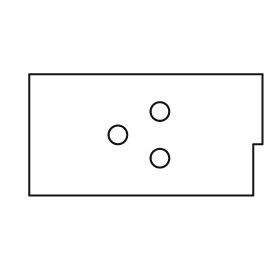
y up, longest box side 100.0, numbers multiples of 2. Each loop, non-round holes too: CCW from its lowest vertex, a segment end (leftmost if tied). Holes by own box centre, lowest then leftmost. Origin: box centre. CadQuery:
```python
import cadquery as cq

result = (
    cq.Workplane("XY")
    .moveTo(-50.0, -26.0)
    .lineTo(46.0, -26.0)
    .lineTo(46.0, -4.0)
    .lineTo(50.0, -4.0)
    .lineTo(50.0, 26.0)
    .lineTo(-50.0, 26.0)
    .close()
    .moveTo(6.0, -10.0)
    .circle(4.0)
    .moveTo(-12.0, 0.0)
    .circle(4.0)
    .moveTo(6.0, 10.0)
    .circle(4.0)
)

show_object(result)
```